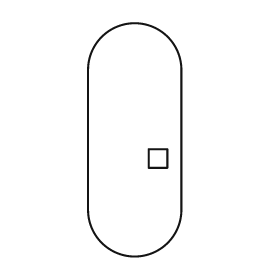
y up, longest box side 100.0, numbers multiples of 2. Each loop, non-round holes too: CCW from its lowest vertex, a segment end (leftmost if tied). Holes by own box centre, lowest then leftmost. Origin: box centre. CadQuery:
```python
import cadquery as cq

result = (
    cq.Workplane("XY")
    .moveTo(-20.0, -30.0)
    .threePointArc((0.0, -50.0), (20.0, -30.0))
    .lineTo(20.0, 30.0)
    .threePointArc((0.0, 50.0), (-20.0, 30.0))
    .close()
    .moveTo(6.0, -12.0)
    .lineTo(14.0, -12.0)
    .lineTo(14.0, -4.0)
    .lineTo(6.0, -4.0)
    .close()
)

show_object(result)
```